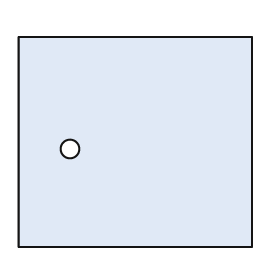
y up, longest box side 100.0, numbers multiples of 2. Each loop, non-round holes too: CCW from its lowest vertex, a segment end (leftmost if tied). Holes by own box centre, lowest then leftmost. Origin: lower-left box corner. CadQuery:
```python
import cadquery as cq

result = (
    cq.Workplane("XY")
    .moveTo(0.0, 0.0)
    .lineTo(100.0, 0.0)
    .lineTo(100.0, 90.0)
    .lineTo(0.0, 90.0)
    .close()
    .moveTo(22.0, 42.0)
    .circle(4.0)
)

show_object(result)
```